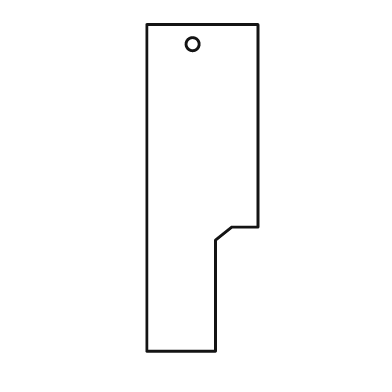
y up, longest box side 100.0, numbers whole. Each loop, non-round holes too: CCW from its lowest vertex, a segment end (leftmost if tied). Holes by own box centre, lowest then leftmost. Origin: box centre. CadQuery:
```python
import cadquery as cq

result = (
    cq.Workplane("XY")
    .moveTo(-17.0, -50.0)
    .lineTo(4.0, -50.0)
    .lineTo(4.0, -16.0)
    .lineTo(9.0, -12.0)
    .lineTo(17.0, -12.0)
    .lineTo(17.0, 50.0)
    .lineTo(-17.0, 50.0)
    .close()
    .moveTo(-3.0, 44.0)
    .circle(2.0)
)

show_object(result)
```